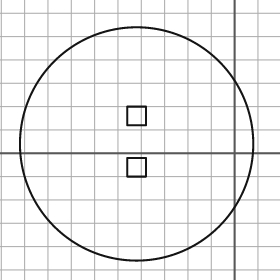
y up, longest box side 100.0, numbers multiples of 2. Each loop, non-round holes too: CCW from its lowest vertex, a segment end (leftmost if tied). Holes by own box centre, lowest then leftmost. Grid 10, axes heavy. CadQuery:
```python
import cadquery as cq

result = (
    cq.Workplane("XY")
    .moveTo(-42.0, 4.0)
    .circle(50.0)
    .moveTo(-46.0, -10.0)
    .lineTo(-38.0, -10.0)
    .lineTo(-38.0, -2.0)
    .lineTo(-46.0, -2.0)
    .close()
    .moveTo(-46.0, 12.0)
    .lineTo(-38.0, 12.0)
    .lineTo(-38.0, 20.0)
    .lineTo(-46.0, 20.0)
    .close()
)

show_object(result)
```